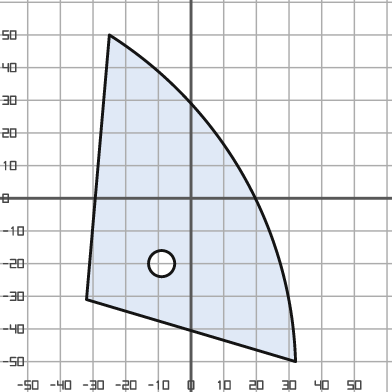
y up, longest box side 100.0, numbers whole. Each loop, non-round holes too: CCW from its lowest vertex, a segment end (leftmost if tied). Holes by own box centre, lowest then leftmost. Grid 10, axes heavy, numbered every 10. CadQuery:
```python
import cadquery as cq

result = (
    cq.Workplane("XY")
    .moveTo(32.0, -50.0)
    .threePointArc((16.0, 7.0), (-25.0, 50.0))
    .lineTo(-32.0, -31.0)
    .close()
    .moveTo(-9.0, -20.0)
    .circle(4.0)
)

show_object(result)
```